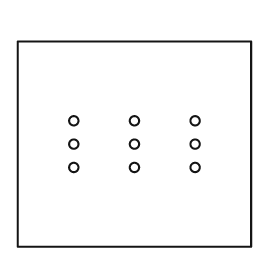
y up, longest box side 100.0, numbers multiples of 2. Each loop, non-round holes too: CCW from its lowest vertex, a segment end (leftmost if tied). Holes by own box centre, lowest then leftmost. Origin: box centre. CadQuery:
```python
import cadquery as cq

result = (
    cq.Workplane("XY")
    .moveTo(-50.0, -44.0)
    .lineTo(50.0, -44.0)
    .lineTo(50.0, 44.0)
    .lineTo(-50.0, 44.0)
    .close()
    .moveTo(-26.0, -10.0)
    .circle(2.0)
    .moveTo(0.0, -10.0)
    .circle(2.0)
    .moveTo(26.0, -10.0)
    .circle(2.0)
    .moveTo(-26.0, 0.0)
    .circle(2.0)
    .moveTo(0.0, 0.0)
    .circle(2.0)
    .moveTo(26.0, 0.0)
    .circle(2.0)
    .moveTo(-26.0, 10.0)
    .circle(2.0)
    .moveTo(0.0, 10.0)
    .circle(2.0)
    .moveTo(26.0, 10.0)
    .circle(2.0)
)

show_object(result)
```